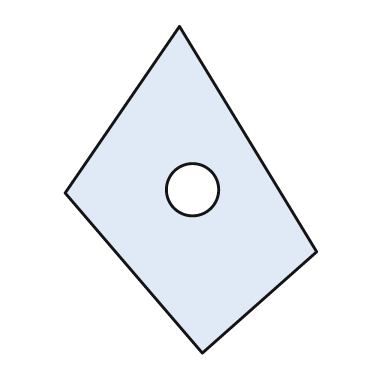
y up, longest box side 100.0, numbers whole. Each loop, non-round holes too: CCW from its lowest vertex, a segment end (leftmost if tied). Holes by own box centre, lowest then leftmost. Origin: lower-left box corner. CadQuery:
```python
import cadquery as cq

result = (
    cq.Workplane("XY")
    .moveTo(42.0, 0.0)
    .lineTo(77.0, 31.0)
    .lineTo(35.0, 100.0)
    .lineTo(0.0, 49.0)
    .close()
    .moveTo(39.0, 50.0)
    .circle(8.0)
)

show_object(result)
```